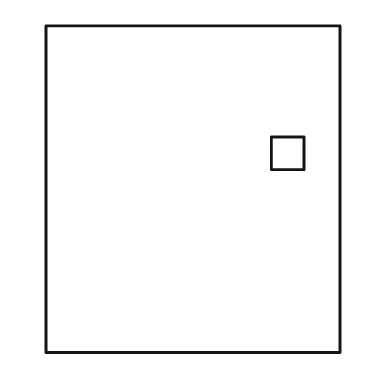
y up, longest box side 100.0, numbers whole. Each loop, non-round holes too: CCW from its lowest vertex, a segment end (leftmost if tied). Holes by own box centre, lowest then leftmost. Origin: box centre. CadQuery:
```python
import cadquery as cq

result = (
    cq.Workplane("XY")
    .moveTo(-45.0, -50.0)
    .lineTo(45.0, -50.0)
    .lineTo(45.0, 50.0)
    .lineTo(-45.0, 50.0)
    .close()
    .moveTo(24.0, 6.0)
    .lineTo(34.0, 6.0)
    .lineTo(34.0, 16.0)
    .lineTo(24.0, 16.0)
    .close()
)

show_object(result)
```